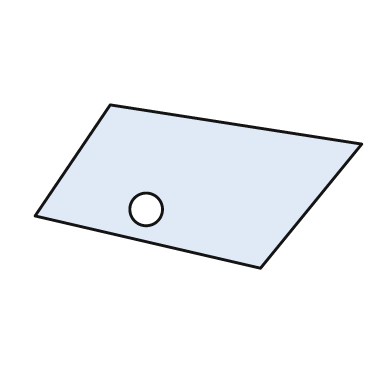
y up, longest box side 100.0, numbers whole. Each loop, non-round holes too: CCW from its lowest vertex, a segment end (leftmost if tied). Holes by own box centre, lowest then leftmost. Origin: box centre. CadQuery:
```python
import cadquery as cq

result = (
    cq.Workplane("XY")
    .moveTo(19.0, -25.0)
    .lineTo(50.0, 13.0)
    .lineTo(-27.0, 25.0)
    .lineTo(-50.0, -9.0)
    .close()
    .moveTo(-16.0, -7.0)
    .circle(5.0)
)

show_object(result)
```